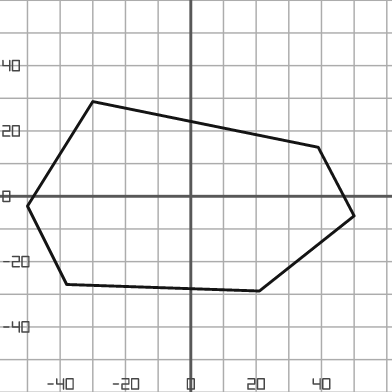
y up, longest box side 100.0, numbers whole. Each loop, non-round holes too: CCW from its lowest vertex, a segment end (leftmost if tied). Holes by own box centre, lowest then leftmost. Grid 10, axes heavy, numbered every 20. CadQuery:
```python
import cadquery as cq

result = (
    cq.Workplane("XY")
    .moveTo(21.0, -29.0)
    .lineTo(50.0, -6.0)
    .lineTo(39.0, 15.0)
    .lineTo(-30.0, 29.0)
    .lineTo(-50.0, -3.0)
    .lineTo(-38.0, -27.0)
    .close()
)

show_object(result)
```